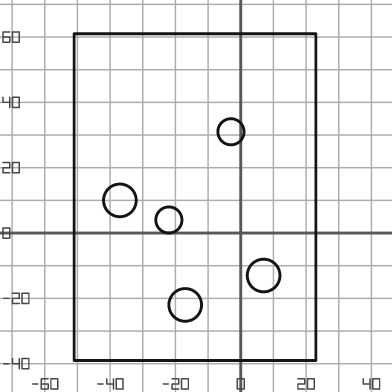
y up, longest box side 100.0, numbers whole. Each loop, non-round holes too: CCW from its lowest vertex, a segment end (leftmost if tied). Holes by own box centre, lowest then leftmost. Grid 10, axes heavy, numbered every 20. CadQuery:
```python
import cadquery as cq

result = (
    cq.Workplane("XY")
    .moveTo(-51.0, -39.0)
    .lineTo(23.0, -39.0)
    .lineTo(23.0, 61.0)
    .lineTo(-51.0, 61.0)
    .close()
    .moveTo(-17.0, -22.0)
    .circle(5.0)
    .moveTo(7.0, -13.0)
    .circle(5.0)
    .moveTo(-22.0, 4.0)
    .circle(4.0)
    .moveTo(-37.0, 10.0)
    .circle(5.0)
    .moveTo(-3.0, 31.0)
    .circle(4.0)
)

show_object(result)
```